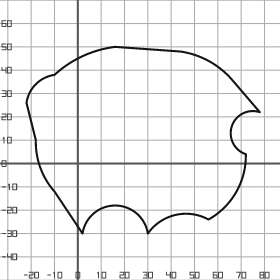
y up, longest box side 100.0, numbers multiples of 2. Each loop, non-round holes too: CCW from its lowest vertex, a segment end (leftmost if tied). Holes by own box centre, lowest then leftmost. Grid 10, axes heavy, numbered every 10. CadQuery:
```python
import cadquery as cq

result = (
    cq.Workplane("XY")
    .moveTo(2.0, -30.0)
    .threePointArc((16.0, -18.0), (30.0, -30.0))
    .threePointArc((42.0, -22.0), (56.0, -24.0))
    .threePointArc((68.0, -12.0), (72.0, 4.0))
    .threePointArc((66.0, 16.0), (78.0, 22.0))
    .lineTo(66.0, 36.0)
    .threePointArc((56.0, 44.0), (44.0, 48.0))
    .lineTo(16.0, 50.0)
    .threePointArc((2.0, 46.0), (-10.0, 38.0))
    .threePointArc((-18.0, 34.0), (-22.0, 26.0))
    .lineTo(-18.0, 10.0)
    .threePointArc((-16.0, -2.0), (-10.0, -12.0))
    .close()
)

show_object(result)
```